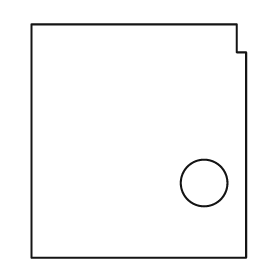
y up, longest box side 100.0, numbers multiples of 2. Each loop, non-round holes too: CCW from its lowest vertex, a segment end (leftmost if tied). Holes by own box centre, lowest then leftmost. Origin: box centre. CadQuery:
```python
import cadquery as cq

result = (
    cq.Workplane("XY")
    .moveTo(-46.0, -50.0)
    .lineTo(46.0, -50.0)
    .lineTo(46.0, 38.0)
    .lineTo(42.0, 38.0)
    .lineTo(42.0, 50.0)
    .lineTo(-46.0, 50.0)
    .close()
    .moveTo(28.0, -18.0)
    .circle(10.0)
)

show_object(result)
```